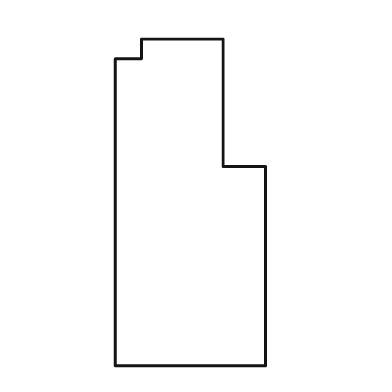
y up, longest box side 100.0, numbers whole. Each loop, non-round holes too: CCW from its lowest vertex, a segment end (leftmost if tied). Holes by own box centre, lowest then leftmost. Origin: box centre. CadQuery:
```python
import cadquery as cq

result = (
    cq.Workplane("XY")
    .moveTo(-23.0, -50.0)
    .lineTo(23.0, -50.0)
    .lineTo(23.0, 11.0)
    .lineTo(10.0, 11.0)
    .lineTo(10.0, 50.0)
    .lineTo(-15.0, 50.0)
    .lineTo(-15.0, 44.0)
    .lineTo(-23.0, 44.0)
    .close()
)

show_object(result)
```